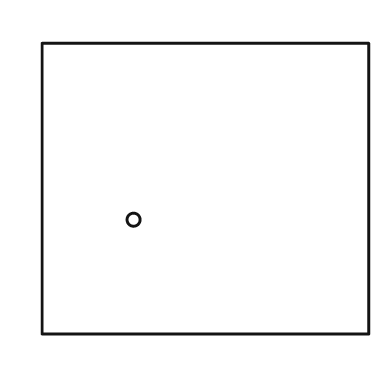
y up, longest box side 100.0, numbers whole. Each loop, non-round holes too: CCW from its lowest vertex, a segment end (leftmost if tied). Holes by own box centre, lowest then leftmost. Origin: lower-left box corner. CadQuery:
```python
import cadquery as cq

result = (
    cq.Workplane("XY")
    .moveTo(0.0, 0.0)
    .lineTo(100.0, 0.0)
    .lineTo(100.0, 89.0)
    .lineTo(0.0, 89.0)
    .close()
    .moveTo(28.0, 35.0)
    .circle(2.0)
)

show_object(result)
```